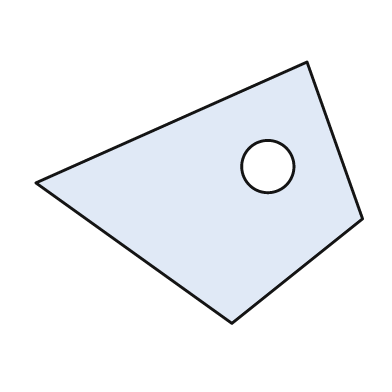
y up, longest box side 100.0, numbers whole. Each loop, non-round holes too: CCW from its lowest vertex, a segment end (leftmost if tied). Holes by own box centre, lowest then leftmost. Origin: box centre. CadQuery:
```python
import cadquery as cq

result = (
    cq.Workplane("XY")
    .moveTo(10.0, -40.0)
    .lineTo(50.0, -8.0)
    .lineTo(33.0, 40.0)
    .lineTo(-50.0, 3.0)
    .close()
    .moveTo(21.0, 8.0)
    .circle(8.0)
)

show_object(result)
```